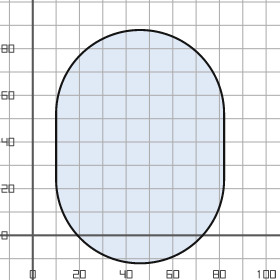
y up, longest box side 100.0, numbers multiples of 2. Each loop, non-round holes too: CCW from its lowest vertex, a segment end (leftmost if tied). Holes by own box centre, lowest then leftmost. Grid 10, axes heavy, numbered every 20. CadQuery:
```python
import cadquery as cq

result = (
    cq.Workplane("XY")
    .moveTo(10.0, 24.0)
    .threePointArc((46.0, -12.0), (82.0, 24.0))
    .lineTo(82.0, 52.0)
    .threePointArc((46.0, 88.0), (10.0, 52.0))
    .close()
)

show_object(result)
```